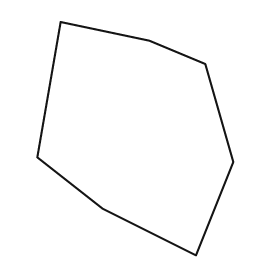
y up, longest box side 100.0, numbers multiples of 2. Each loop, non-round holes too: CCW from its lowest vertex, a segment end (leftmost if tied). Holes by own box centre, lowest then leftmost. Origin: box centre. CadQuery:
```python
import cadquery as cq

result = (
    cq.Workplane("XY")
    .moveTo(26.0, -50.0)
    .lineTo(42.0, -10.0)
    .lineTo(30.0, 32.0)
    .lineTo(6.0, 42.0)
    .lineTo(-32.0, 50.0)
    .lineTo(-42.0, -8.0)
    .lineTo(-14.0, -30.0)
    .close()
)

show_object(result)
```